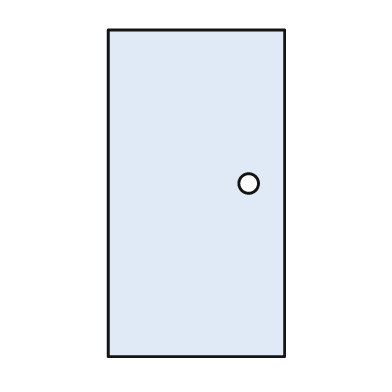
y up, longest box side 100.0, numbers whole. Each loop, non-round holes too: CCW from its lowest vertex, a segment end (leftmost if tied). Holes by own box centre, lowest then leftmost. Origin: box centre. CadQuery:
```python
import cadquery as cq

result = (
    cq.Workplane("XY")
    .moveTo(-27.0, -50.0)
    .lineTo(27.0, -50.0)
    .lineTo(27.0, 50.0)
    .lineTo(-27.0, 50.0)
    .close()
    .moveTo(16.0, 3.0)
    .circle(3.0)
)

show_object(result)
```